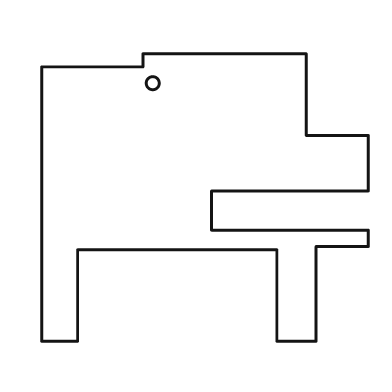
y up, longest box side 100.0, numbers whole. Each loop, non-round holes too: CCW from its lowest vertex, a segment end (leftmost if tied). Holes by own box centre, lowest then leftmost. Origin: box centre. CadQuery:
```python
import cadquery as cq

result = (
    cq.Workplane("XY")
    .moveTo(-50.0, -44.0)
    .lineTo(-39.0, -44.0)
    .lineTo(-39.0, -16.0)
    .lineTo(22.0, -16.0)
    .lineTo(22.0, -44.0)
    .lineTo(34.0, -44.0)
    .lineTo(34.0, -15.0)
    .lineTo(50.0, -15.0)
    .lineTo(50.0, -10.0)
    .lineTo(2.0, -10.0)
    .lineTo(2.0, 2.0)
    .lineTo(50.0, 2.0)
    .lineTo(50.0, 19.0)
    .lineTo(31.0, 19.0)
    .lineTo(31.0, 44.0)
    .lineTo(-19.0, 44.0)
    .lineTo(-19.0, 40.0)
    .lineTo(-50.0, 40.0)
    .close()
    .moveTo(-16.0, 35.0)
    .circle(2.0)
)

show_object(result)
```